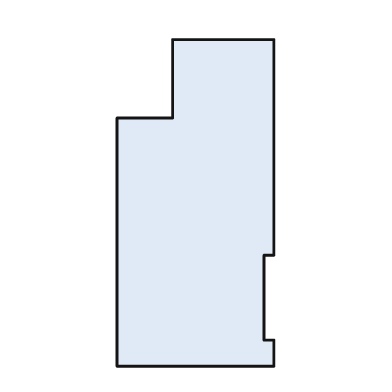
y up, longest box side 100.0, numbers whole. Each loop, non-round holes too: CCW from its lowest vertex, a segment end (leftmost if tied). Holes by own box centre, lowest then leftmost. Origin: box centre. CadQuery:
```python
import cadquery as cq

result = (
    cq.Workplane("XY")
    .moveTo(-24.0, -50.0)
    .lineTo(24.0, -50.0)
    .lineTo(24.0, -42.0)
    .lineTo(21.0, -42.0)
    .lineTo(21.0, -16.0)
    .lineTo(24.0, -16.0)
    .lineTo(24.0, 50.0)
    .lineTo(-7.0, 50.0)
    .lineTo(-7.0, 26.0)
    .lineTo(-24.0, 26.0)
    .close()
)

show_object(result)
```